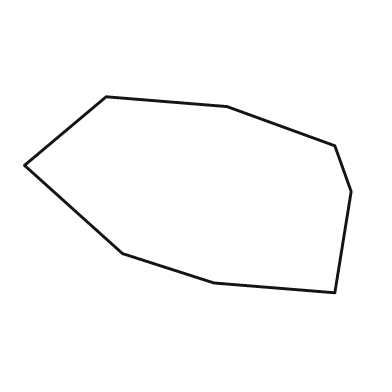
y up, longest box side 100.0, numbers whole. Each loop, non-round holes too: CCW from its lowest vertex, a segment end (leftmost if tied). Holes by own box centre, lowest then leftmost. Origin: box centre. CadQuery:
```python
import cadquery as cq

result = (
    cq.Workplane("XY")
    .moveTo(45.0, -30.0)
    .lineTo(50.0, 1.0)
    .lineTo(45.0, 15.0)
    .lineTo(12.0, 27.0)
    .lineTo(-25.0, 30.0)
    .lineTo(-50.0, 9.0)
    .lineTo(-20.0, -18.0)
    .lineTo(8.0, -27.0)
    .close()
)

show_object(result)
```